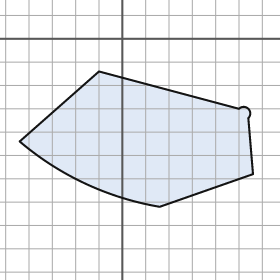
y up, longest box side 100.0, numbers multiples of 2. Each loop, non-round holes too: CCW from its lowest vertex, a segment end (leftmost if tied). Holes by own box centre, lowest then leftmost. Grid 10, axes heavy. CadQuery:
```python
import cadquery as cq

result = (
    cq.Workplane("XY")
    .moveTo(16.0, -72.0)
    .lineTo(56.0, -58.0)
    .lineTo(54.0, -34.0)
    .threePointArc((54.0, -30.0), (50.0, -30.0))
    .lineTo(-10.0, -14.0)
    .lineTo(-44.0, -44.0)
    .threePointArc((-16.0, -62.0), (16.0, -72.0))
    .close()
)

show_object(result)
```